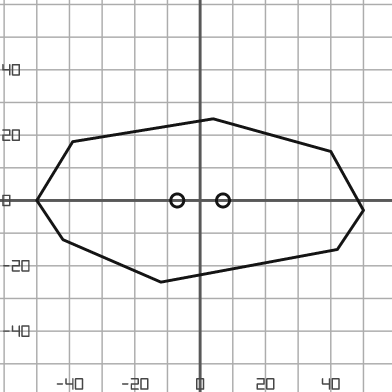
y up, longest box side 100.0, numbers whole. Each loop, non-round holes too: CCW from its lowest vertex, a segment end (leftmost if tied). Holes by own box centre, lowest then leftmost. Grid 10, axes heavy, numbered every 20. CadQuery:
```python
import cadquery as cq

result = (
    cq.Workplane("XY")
    .moveTo(-12.0, -25.0)
    .lineTo(42.0, -15.0)
    .lineTo(50.0, -3.0)
    .lineTo(40.0, 15.0)
    .lineTo(4.0, 25.0)
    .lineTo(-39.0, 18.0)
    .lineTo(-50.0, 0.0)
    .lineTo(-42.0, -12.0)
    .close()
    .moveTo(-7.0, 0.0)
    .circle(2.0)
    .moveTo(7.0, 0.0)
    .circle(2.0)
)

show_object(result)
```